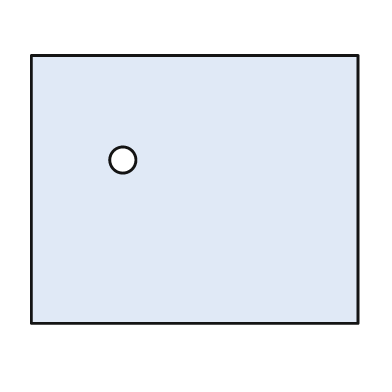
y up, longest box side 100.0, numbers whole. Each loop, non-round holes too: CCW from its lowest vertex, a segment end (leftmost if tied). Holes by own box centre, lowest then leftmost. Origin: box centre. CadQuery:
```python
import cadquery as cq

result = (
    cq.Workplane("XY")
    .moveTo(-50.0, -41.0)
    .lineTo(50.0, -41.0)
    .lineTo(50.0, 41.0)
    .lineTo(-50.0, 41.0)
    .close()
    .moveTo(-22.0, 9.0)
    .circle(4.0)
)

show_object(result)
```